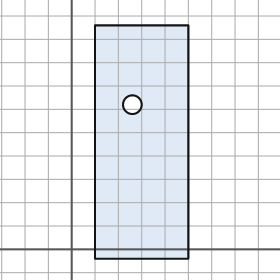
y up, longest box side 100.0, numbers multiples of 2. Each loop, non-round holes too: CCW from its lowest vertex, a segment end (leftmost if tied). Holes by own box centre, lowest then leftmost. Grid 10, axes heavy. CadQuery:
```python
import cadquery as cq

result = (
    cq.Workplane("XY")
    .moveTo(10.0, -4.0)
    .lineTo(50.0, -4.0)
    .lineTo(50.0, 96.0)
    .lineTo(10.0, 96.0)
    .close()
    .moveTo(26.0, 62.0)
    .circle(4.0)
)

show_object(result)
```